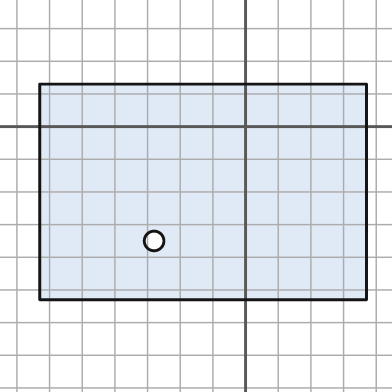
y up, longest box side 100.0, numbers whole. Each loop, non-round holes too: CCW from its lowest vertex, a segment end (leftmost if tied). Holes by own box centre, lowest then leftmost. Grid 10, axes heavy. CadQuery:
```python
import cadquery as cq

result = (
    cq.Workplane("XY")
    .moveTo(-63.0, -53.0)
    .lineTo(37.0, -53.0)
    .lineTo(37.0, 13.0)
    .lineTo(-63.0, 13.0)
    .close()
    .moveTo(-28.0, -35.0)
    .circle(3.0)
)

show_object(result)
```